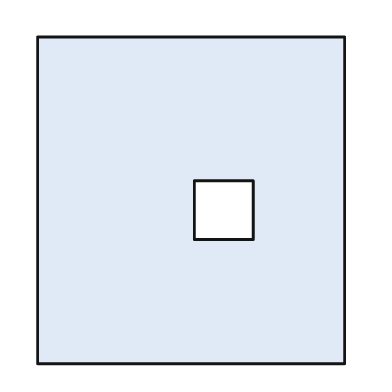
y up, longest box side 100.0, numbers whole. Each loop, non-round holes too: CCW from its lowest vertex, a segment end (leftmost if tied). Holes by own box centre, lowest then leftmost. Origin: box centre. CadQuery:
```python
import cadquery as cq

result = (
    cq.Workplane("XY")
    .moveTo(-47.0, -50.0)
    .lineTo(47.0, -50.0)
    .lineTo(47.0, 50.0)
    .lineTo(-47.0, 50.0)
    .close()
    .moveTo(1.0, -12.0)
    .lineTo(19.0, -12.0)
    .lineTo(19.0, 6.0)
    .lineTo(1.0, 6.0)
    .close()
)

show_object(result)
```